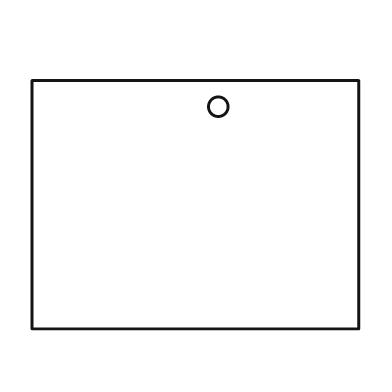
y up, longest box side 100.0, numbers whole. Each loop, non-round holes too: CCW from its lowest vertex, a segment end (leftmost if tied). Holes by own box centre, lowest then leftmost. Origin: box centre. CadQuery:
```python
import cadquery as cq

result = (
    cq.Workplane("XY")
    .moveTo(-50.0, -38.0)
    .lineTo(50.0, -38.0)
    .lineTo(50.0, 38.0)
    .lineTo(-50.0, 38.0)
    .close()
    .moveTo(7.0, 30.0)
    .circle(3.0)
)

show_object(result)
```